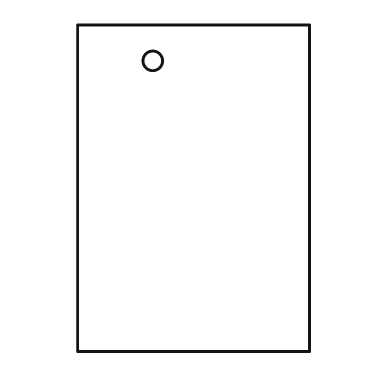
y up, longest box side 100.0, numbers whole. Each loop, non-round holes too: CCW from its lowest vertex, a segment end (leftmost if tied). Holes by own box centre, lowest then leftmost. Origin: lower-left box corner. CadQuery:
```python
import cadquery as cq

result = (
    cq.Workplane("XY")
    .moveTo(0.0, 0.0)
    .lineTo(71.0, 0.0)
    .lineTo(71.0, 100.0)
    .lineTo(0.0, 100.0)
    .close()
    .moveTo(23.0, 89.0)
    .circle(3.0)
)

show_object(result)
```